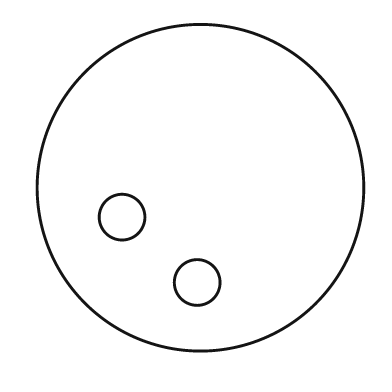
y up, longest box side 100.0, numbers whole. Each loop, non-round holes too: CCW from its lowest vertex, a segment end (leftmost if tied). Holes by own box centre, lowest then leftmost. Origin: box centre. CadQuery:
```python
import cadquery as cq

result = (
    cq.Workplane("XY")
    .moveTo(0.0, 0.0)
    .circle(50.0)
    .moveTo(-1.0, -29.0)
    .circle(7.0)
    .moveTo(-24.0, -9.0)
    .circle(7.0)
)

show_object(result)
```